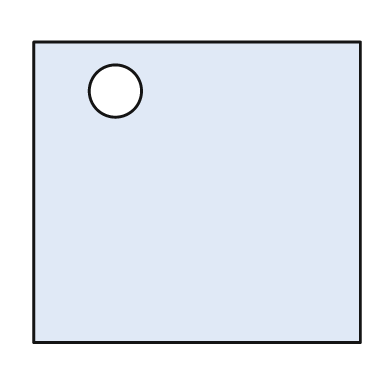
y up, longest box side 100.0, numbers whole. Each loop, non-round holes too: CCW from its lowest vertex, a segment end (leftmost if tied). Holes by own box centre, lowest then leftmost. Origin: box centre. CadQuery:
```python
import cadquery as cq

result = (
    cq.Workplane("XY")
    .moveTo(-50.0, -46.0)
    .lineTo(50.0, -46.0)
    .lineTo(50.0, 46.0)
    .lineTo(-50.0, 46.0)
    .close()
    .moveTo(-25.0, 31.0)
    .circle(8.0)
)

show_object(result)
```